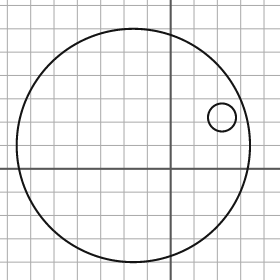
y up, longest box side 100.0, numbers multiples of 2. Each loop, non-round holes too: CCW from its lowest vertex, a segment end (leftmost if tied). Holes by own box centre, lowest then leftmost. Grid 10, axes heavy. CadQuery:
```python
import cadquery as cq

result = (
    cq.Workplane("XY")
    .moveTo(-16.0, 10.0)
    .circle(50.0)
    .moveTo(22.0, 22.0)
    .circle(6.0)
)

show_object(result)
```